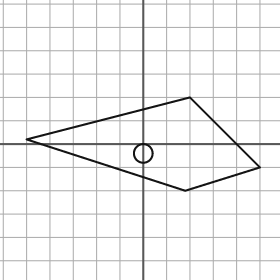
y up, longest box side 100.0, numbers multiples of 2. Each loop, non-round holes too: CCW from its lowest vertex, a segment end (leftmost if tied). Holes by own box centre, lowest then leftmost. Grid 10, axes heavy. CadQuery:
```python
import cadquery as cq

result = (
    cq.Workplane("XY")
    .moveTo(18.0, -20.0)
    .lineTo(50.0, -10.0)
    .lineTo(20.0, 20.0)
    .lineTo(-50.0, 2.0)
    .close()
    .moveTo(0.0, -4.0)
    .circle(4.0)
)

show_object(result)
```